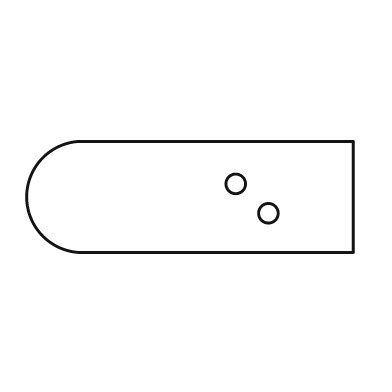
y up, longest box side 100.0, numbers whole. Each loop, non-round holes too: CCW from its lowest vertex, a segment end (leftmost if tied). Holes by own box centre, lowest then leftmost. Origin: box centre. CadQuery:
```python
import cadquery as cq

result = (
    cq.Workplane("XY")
    .moveTo(-34.0, -17.0)
    .lineTo(50.0, -17.0)
    .lineTo(50.0, 17.0)
    .lineTo(-34.0, 17.0)
    .threePointArc((-50.0, 0.0), (-34.0, -17.0))
    .close()
    .moveTo(24.0, -5.0)
    .circle(3.0)
    .moveTo(14.0, 4.0)
    .circle(3.0)
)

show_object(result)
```